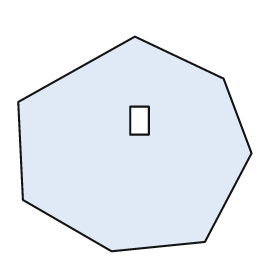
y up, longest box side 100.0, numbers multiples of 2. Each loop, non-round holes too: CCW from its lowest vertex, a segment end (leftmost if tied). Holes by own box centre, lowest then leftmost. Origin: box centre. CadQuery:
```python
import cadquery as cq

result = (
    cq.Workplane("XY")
    .moveTo(-10.0, -46.0)
    .lineTo(30.0, -42.0)
    .lineTo(50.0, -4.0)
    .lineTo(38.0, 28.0)
    .lineTo(0.0, 46.0)
    .lineTo(-50.0, 18.0)
    .lineTo(-48.0, -24.0)
    .close()
    .moveTo(-2.0, 4.0)
    .lineTo(6.0, 4.0)
    .lineTo(6.0, 16.0)
    .lineTo(-2.0, 16.0)
    .close()
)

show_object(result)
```